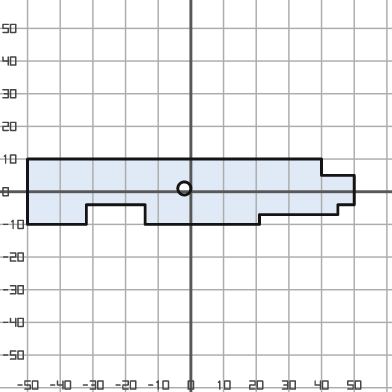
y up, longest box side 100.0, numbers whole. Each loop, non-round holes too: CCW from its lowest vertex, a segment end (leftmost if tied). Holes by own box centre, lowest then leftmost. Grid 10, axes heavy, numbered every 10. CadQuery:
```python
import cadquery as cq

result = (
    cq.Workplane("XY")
    .moveTo(-50.0, -10.0)
    .lineTo(-32.0, -10.0)
    .lineTo(-32.0, -4.0)
    .lineTo(-14.0, -4.0)
    .lineTo(-14.0, -10.0)
    .lineTo(21.0, -10.0)
    .lineTo(21.0, -7.0)
    .lineTo(45.0, -7.0)
    .lineTo(45.0, -4.0)
    .lineTo(50.0, -4.0)
    .lineTo(50.0, 5.0)
    .lineTo(40.0, 5.0)
    .lineTo(40.0, 10.0)
    .lineTo(-50.0, 10.0)
    .close()
    .moveTo(-2.0, 1.0)
    .circle(2.0)
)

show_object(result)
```